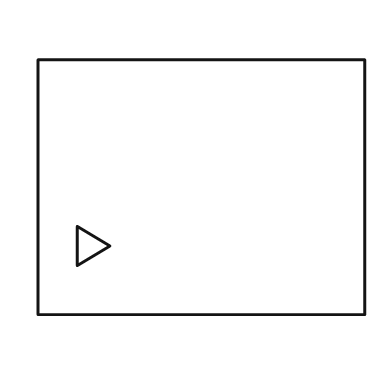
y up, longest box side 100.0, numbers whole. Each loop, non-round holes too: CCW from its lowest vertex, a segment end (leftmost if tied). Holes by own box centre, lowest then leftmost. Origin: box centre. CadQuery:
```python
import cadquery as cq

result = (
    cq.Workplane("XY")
    .moveTo(-50.0, -39.0)
    .lineTo(50.0, -39.0)
    .lineTo(50.0, 39.0)
    .lineTo(-50.0, 39.0)
    .close()
    .moveTo(-38.0, -24.0)
    .lineTo(-28.0, -18.0)
    .lineTo(-38.0, -12.0)
    .close()
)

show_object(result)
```